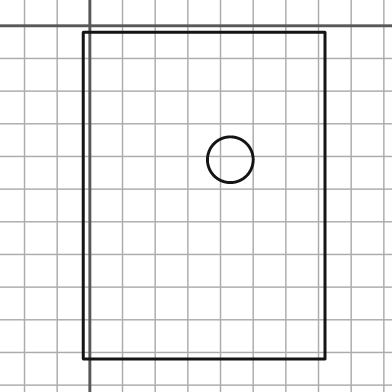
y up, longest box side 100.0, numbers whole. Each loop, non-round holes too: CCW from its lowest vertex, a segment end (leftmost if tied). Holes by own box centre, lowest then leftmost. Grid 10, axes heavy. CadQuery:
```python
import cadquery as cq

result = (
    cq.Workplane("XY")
    .moveTo(-2.0, -102.0)
    .lineTo(72.0, -102.0)
    .lineTo(72.0, -2.0)
    .lineTo(-2.0, -2.0)
    .close()
    .moveTo(43.0, -41.0)
    .circle(7.0)
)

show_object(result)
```